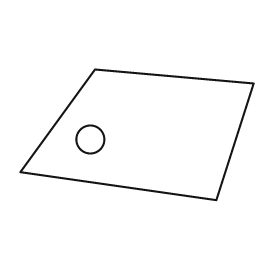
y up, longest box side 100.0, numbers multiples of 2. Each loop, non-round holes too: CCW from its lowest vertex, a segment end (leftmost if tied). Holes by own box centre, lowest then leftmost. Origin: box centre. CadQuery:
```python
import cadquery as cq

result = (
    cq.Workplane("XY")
    .moveTo(34.0, -28.0)
    .lineTo(50.0, 22.0)
    .lineTo(-18.0, 28.0)
    .lineTo(-50.0, -16.0)
    .close()
    .moveTo(-20.0, -2.0)
    .circle(6.0)
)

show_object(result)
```